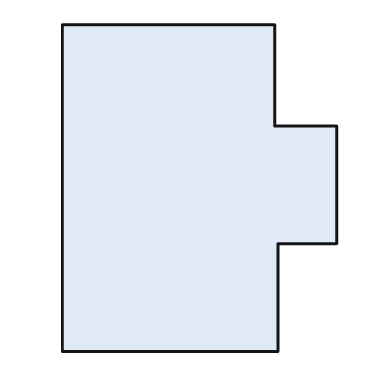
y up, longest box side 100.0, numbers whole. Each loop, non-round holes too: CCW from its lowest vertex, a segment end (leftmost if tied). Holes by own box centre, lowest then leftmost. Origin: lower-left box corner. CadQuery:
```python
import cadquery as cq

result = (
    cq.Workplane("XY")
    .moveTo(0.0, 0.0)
    .lineTo(66.0, 0.0)
    .lineTo(66.0, 33.0)
    .lineTo(84.0, 33.0)
    .lineTo(84.0, 69.0)
    .lineTo(65.0, 69.0)
    .lineTo(65.0, 100.0)
    .lineTo(0.0, 100.0)
    .close()
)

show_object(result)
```